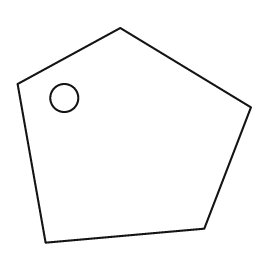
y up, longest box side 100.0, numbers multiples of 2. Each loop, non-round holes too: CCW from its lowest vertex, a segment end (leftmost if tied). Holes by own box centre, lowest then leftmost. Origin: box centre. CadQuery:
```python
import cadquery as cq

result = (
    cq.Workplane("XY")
    .moveTo(-38.0, -46.0)
    .lineTo(30.0, -40.0)
    .lineTo(50.0, 12.0)
    .lineTo(-6.0, 46.0)
    .lineTo(-50.0, 22.0)
    .close()
    .moveTo(-30.0, 16.0)
    .circle(6.0)
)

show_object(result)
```